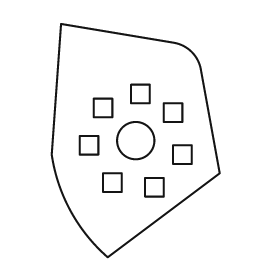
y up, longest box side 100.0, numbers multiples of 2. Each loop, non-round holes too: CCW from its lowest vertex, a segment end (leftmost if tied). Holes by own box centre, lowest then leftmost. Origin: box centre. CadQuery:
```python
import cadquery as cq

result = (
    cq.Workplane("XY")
    .moveTo(-12.0, -50.0)
    .lineTo(36.0, -14.0)
    .lineTo(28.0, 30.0)
    .threePointArc((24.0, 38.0), (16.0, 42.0))
    .lineTo(-32.0, 50.0)
    .lineTo(-36.0, -6.0)
    .threePointArc((-28.0, -30.0), (-12.0, -50.0))
    .close()
    .moveTo(4.0, -24.0)
    .lineTo(12.0, -24.0)
    .lineTo(12.0, -16.0)
    .lineTo(4.0, -16.0)
    .close()
    .moveTo(-14.0, -22.0)
    .lineTo(-6.0, -22.0)
    .lineTo(-6.0, -14.0)
    .lineTo(-14.0, -14.0)
    .close()
    .moveTo(16.0, -10.0)
    .lineTo(24.0, -10.0)
    .lineTo(24.0, -2.0)
    .lineTo(16.0, -2.0)
    .close()
    .moveTo(-24.0, -6.0)
    .lineTo(-16.0, -6.0)
    .lineTo(-16.0, 2.0)
    .lineTo(-24.0, 2.0)
    .close()
    .moveTo(0.0, 0.0)
    .circle(8.0)
    .moveTo(12.0, 8.0)
    .lineTo(20.0, 8.0)
    .lineTo(20.0, 16.0)
    .lineTo(12.0, 16.0)
    .close()
    .moveTo(-18.0, 10.0)
    .lineTo(-10.0, 10.0)
    .lineTo(-10.0, 18.0)
    .lineTo(-18.0, 18.0)
    .close()
    .moveTo(-2.0, 16.0)
    .lineTo(6.0, 16.0)
    .lineTo(6.0, 24.0)
    .lineTo(-2.0, 24.0)
    .close()
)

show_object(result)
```